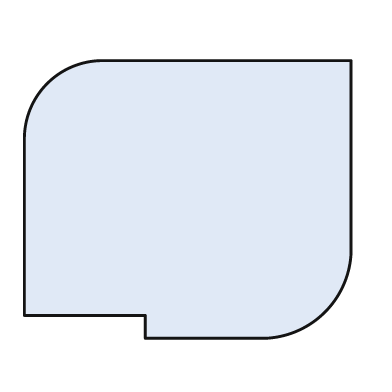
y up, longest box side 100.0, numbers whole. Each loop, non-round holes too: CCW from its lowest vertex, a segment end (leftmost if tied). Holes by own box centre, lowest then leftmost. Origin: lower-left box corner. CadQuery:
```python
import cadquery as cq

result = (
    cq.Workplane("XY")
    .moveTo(37.0, 0.0)
    .lineTo(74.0, 0.0)
    .threePointArc((92.0, 8.0), (100.0, 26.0))
    .lineTo(100.0, 85.0)
    .lineTo(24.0, 85.0)
    .threePointArc((7.0, 78.0), (0.0, 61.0))
    .lineTo(0.0, 7.0)
    .lineTo(37.0, 7.0)
    .close()
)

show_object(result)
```